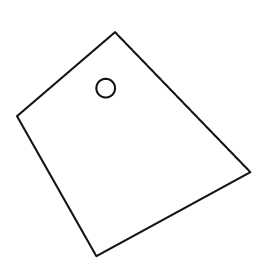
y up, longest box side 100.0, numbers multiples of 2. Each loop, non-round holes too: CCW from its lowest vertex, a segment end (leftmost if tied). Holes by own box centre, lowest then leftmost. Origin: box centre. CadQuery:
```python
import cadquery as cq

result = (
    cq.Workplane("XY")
    .moveTo(-16.0, -48.0)
    .lineTo(50.0, -12.0)
    .lineTo(-8.0, 48.0)
    .lineTo(-50.0, 12.0)
    .close()
    .moveTo(-12.0, 24.0)
    .circle(4.0)
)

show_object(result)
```